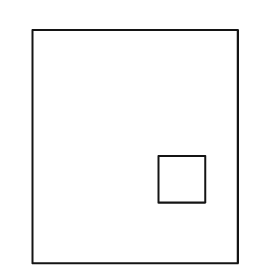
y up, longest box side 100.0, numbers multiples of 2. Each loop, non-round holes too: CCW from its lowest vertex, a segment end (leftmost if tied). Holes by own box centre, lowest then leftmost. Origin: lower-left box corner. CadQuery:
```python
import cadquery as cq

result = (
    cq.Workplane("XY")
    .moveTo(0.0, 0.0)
    .lineTo(88.0, 0.0)
    .lineTo(88.0, 100.0)
    .lineTo(0.0, 100.0)
    .close()
    .moveTo(54.0, 26.0)
    .lineTo(74.0, 26.0)
    .lineTo(74.0, 46.0)
    .lineTo(54.0, 46.0)
    .close()
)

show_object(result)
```